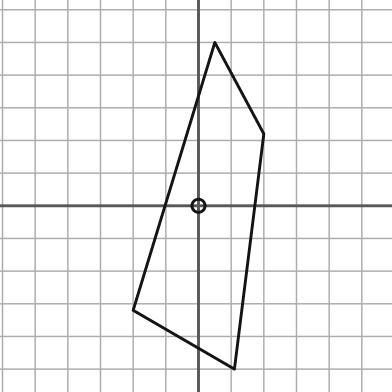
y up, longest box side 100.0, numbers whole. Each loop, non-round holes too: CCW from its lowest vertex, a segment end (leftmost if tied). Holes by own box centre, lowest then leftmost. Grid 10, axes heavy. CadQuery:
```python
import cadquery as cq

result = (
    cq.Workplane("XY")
    .moveTo(11.0, -50.0)
    .lineTo(20.0, 22.0)
    .lineTo(5.0, 50.0)
    .lineTo(-20.0, -32.0)
    .close()
    .moveTo(0.0, 0.0)
    .circle(2.0)
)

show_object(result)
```